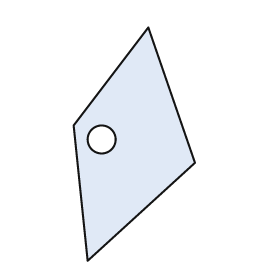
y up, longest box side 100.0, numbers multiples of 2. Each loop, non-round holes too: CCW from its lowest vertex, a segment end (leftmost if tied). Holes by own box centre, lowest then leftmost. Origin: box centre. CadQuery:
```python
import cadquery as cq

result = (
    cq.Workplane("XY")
    .moveTo(-20.0, -50.0)
    .lineTo(26.0, -8.0)
    .lineTo(6.0, 50.0)
    .lineTo(-26.0, 8.0)
    .close()
    .moveTo(-14.0, 2.0)
    .circle(6.0)
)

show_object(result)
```